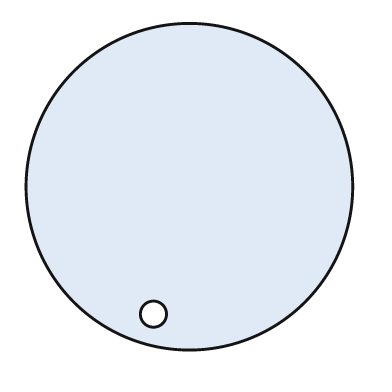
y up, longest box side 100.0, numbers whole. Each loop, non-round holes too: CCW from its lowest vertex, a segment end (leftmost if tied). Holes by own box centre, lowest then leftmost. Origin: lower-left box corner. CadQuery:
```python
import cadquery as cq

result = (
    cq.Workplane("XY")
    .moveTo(50.0, 50.0)
    .circle(50.0)
    .moveTo(39.0, 11.0)
    .circle(4.0)
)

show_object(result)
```